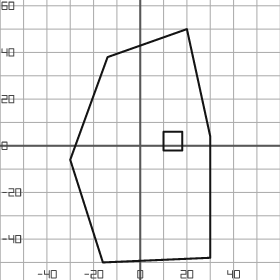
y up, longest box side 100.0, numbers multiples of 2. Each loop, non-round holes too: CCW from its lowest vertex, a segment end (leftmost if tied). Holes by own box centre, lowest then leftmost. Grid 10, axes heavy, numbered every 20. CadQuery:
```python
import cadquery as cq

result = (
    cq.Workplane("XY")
    .moveTo(-16.0, -50.0)
    .lineTo(30.0, -48.0)
    .lineTo(30.0, 4.0)
    .lineTo(20.0, 50.0)
    .lineTo(-14.0, 38.0)
    .lineTo(-30.0, -6.0)
    .close()
    .moveTo(10.0, -2.0)
    .lineTo(18.0, -2.0)
    .lineTo(18.0, 6.0)
    .lineTo(10.0, 6.0)
    .close()
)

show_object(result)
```